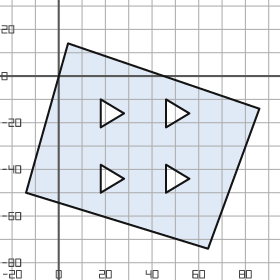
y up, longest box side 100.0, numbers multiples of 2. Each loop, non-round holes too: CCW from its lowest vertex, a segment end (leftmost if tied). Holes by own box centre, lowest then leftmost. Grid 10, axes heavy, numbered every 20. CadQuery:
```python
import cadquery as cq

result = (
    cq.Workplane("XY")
    .moveTo(64.0, -74.0)
    .lineTo(86.0, -14.0)
    .lineTo(4.0, 14.0)
    .lineTo(-14.0, -50.0)
    .close()
    .moveTo(18.0, -50.0)
    .lineTo(28.0, -44.0)
    .lineTo(18.0, -38.0)
    .close()
    .moveTo(46.0, -50.0)
    .lineTo(56.0, -44.0)
    .lineTo(46.0, -38.0)
    .close()
    .moveTo(18.0, -22.0)
    .lineTo(28.0, -16.0)
    .lineTo(18.0, -10.0)
    .close()
    .moveTo(46.0, -22.0)
    .lineTo(56.0, -16.0)
    .lineTo(46.0, -10.0)
    .close()
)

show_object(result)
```